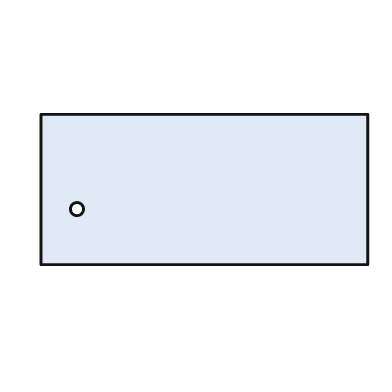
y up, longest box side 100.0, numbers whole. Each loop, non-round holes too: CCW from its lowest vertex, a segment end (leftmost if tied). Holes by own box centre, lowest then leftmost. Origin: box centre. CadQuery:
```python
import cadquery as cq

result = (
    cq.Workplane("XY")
    .moveTo(-50.0, -23.0)
    .lineTo(50.0, -23.0)
    .lineTo(50.0, 23.0)
    .lineTo(-50.0, 23.0)
    .close()
    .moveTo(-39.0, -6.0)
    .circle(2.0)
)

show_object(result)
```